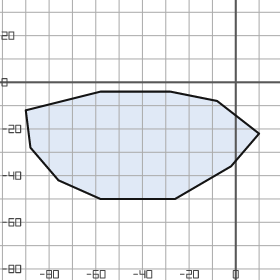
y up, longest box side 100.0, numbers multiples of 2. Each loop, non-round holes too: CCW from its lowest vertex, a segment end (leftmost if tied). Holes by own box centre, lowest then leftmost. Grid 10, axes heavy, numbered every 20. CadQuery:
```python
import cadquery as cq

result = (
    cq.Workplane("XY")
    .moveTo(-58.0, -50.0)
    .lineTo(-26.0, -50.0)
    .lineTo(-2.0, -36.0)
    .lineTo(10.0, -22.0)
    .lineTo(-8.0, -8.0)
    .lineTo(-28.0, -4.0)
    .lineTo(-58.0, -4.0)
    .lineTo(-90.0, -12.0)
    .lineTo(-88.0, -28.0)
    .lineTo(-76.0, -42.0)
    .close()
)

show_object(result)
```